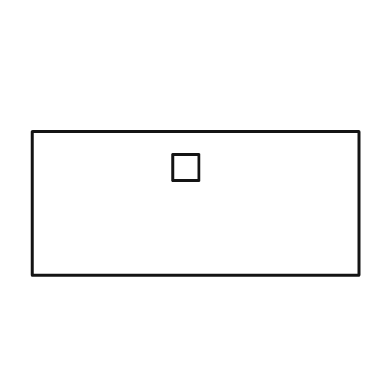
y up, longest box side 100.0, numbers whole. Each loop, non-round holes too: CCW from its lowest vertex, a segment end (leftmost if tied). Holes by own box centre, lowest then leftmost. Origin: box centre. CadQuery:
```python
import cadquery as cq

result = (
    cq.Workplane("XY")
    .moveTo(-50.0, -22.0)
    .lineTo(50.0, -22.0)
    .lineTo(50.0, 22.0)
    .lineTo(-50.0, 22.0)
    .close()
    .moveTo(-7.0, 7.0)
    .lineTo(1.0, 7.0)
    .lineTo(1.0, 15.0)
    .lineTo(-7.0, 15.0)
    .close()
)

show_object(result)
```